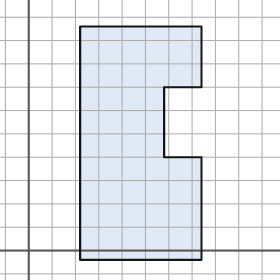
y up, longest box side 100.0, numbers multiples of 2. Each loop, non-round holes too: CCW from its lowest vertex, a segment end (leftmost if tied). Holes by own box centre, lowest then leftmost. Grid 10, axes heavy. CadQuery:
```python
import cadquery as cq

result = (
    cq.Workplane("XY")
    .moveTo(22.0, -4.0)
    .lineTo(74.0, -4.0)
    .lineTo(74.0, 40.0)
    .lineTo(58.0, 40.0)
    .lineTo(58.0, 70.0)
    .lineTo(74.0, 70.0)
    .lineTo(74.0, 96.0)
    .lineTo(22.0, 96.0)
    .close()
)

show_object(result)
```